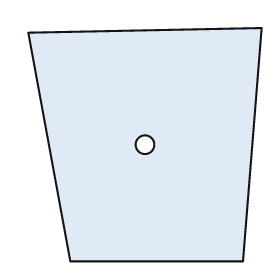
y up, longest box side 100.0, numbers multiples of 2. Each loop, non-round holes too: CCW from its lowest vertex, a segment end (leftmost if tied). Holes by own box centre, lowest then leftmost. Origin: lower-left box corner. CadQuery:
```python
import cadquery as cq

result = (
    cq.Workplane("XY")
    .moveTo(18.0, 0.0)
    .lineTo(92.0, 0.0)
    .lineTo(100.0, 100.0)
    .lineTo(0.0, 98.0)
    .close()
    .moveTo(50.0, 50.0)
    .circle(4.0)
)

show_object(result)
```